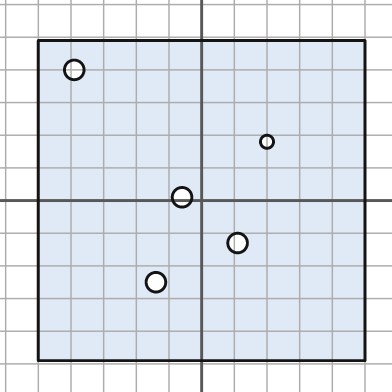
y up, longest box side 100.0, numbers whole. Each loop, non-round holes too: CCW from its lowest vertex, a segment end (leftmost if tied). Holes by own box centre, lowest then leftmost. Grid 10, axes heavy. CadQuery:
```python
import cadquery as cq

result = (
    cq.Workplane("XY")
    .moveTo(-50.0, -49.0)
    .lineTo(50.0, -49.0)
    .lineTo(50.0, 49.0)
    .lineTo(-50.0, 49.0)
    .close()
    .moveTo(-14.0, -25.0)
    .circle(3.0)
    .moveTo(11.0, -13.0)
    .circle(3.0)
    .moveTo(-6.0, 1.0)
    .circle(3.0)
    .moveTo(20.0, 18.0)
    .circle(2.0)
    .moveTo(-39.0, 40.0)
    .circle(3.0)
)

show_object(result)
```